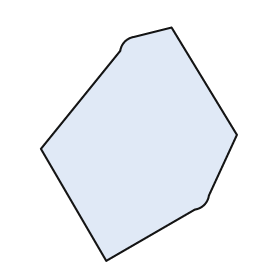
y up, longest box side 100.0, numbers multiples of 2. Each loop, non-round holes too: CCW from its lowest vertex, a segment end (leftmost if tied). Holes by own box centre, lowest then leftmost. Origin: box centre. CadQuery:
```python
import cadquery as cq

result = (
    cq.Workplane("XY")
    .moveTo(-14.0, -50.0)
    .lineTo(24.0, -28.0)
    .threePointArc((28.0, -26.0), (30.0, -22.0))
    .lineTo(42.0, 4.0)
    .lineTo(14.0, 50.0)
    .lineTo(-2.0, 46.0)
    .threePointArc((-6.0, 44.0), (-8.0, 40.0))
    .lineTo(-42.0, -2.0)
    .close()
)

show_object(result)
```